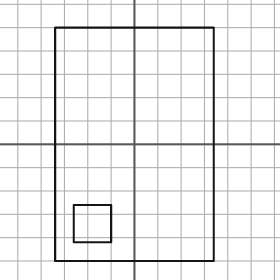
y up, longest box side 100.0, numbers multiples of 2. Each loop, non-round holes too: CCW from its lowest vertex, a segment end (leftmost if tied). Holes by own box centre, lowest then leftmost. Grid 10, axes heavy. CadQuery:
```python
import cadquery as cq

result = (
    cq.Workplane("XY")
    .moveTo(-34.0, -50.0)
    .lineTo(34.0, -50.0)
    .lineTo(34.0, 50.0)
    .lineTo(-34.0, 50.0)
    .close()
    .moveTo(-26.0, -42.0)
    .lineTo(-10.0, -42.0)
    .lineTo(-10.0, -26.0)
    .lineTo(-26.0, -26.0)
    .close()
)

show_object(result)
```